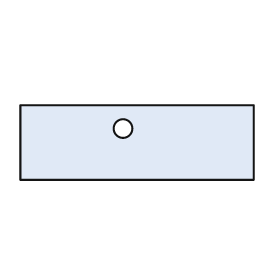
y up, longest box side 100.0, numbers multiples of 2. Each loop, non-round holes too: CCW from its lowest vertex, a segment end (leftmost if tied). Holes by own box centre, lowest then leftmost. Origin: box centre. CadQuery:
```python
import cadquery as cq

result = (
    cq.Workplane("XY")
    .moveTo(-50.0, -16.0)
    .lineTo(50.0, -16.0)
    .lineTo(50.0, 16.0)
    .lineTo(-50.0, 16.0)
    .close()
    .moveTo(-6.0, 6.0)
    .circle(4.0)
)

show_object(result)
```